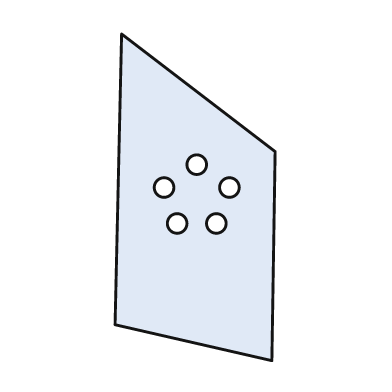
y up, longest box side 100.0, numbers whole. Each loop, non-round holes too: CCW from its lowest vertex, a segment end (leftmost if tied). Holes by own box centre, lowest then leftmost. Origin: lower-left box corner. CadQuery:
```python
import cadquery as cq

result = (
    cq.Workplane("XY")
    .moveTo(48.0, 0.0)
    .lineTo(49.0, 64.0)
    .lineTo(2.0, 100.0)
    .lineTo(0.0, 11.0)
    .close()
    .moveTo(19.0, 42.0)
    .circle(3.0)
    .moveTo(31.0, 42.0)
    .circle(3.0)
    .moveTo(15.0, 53.0)
    .circle(3.0)
    .moveTo(35.0, 53.0)
    .circle(3.0)
    .moveTo(25.0, 60.0)
    .circle(3.0)
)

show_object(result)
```